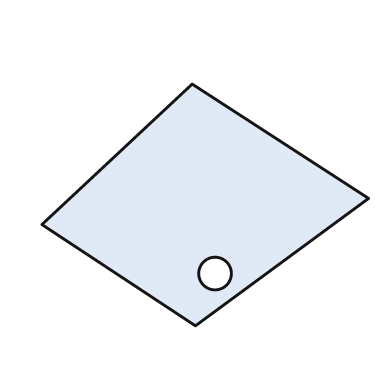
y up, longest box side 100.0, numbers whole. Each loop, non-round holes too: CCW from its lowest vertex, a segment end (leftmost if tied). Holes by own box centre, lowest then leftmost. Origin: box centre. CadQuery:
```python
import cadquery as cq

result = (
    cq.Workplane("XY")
    .moveTo(-3.0, -37.0)
    .lineTo(50.0, 2.0)
    .lineTo(-4.0, 37.0)
    .lineTo(-50.0, -6.0)
    .close()
    .moveTo(3.0, -21.0)
    .circle(5.0)
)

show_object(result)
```